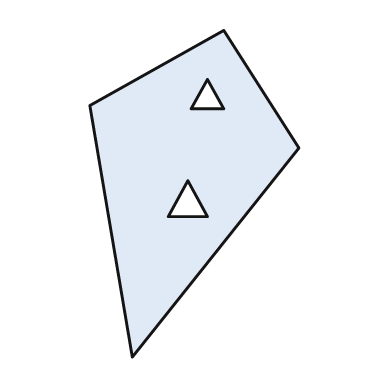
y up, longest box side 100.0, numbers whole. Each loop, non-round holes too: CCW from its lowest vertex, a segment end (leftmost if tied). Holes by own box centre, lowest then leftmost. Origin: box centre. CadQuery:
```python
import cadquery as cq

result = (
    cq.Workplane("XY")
    .moveTo(-19.0, -50.0)
    .lineTo(32.0, 14.0)
    .lineTo(9.0, 50.0)
    .lineTo(-32.0, 27.0)
    .close()
    .moveTo(-8.0, -7.0)
    .lineTo(4.0, -7.0)
    .lineTo(-2.0, 4.0)
    .close()
    .moveTo(-1.0, 26.0)
    .lineTo(9.0, 26.0)
    .lineTo(4.0, 35.0)
    .close()
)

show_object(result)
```